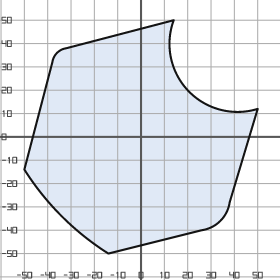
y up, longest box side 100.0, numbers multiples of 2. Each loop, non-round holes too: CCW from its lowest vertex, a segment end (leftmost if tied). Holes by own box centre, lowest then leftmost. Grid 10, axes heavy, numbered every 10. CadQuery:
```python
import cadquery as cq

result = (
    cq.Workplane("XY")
    .moveTo(-14.0, -50.0)
    .lineTo(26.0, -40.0)
    .threePointArc((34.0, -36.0), (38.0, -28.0))
    .lineTo(50.0, 12.0)
    .threePointArc((20.0, 20.0), (14.0, 50.0))
    .lineTo(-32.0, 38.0)
    .threePointArc((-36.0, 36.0), (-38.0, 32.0))
    .lineTo(-50.0, -14.0)
    .threePointArc((-34.0, -34.0), (-14.0, -50.0))
    .close()
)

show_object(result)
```